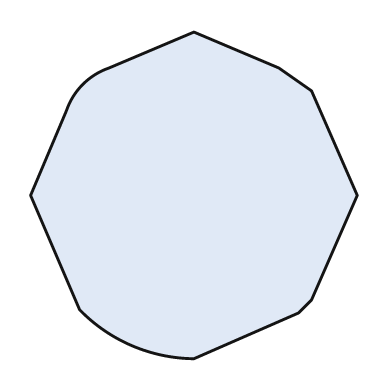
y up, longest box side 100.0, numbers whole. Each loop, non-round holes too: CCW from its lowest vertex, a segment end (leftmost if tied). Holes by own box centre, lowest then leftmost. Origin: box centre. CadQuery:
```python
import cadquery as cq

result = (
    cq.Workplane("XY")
    .moveTo(0.0, -50.0)
    .lineTo(32.0, -36.0)
    .lineTo(36.0, -32.0)
    .lineTo(50.0, 0.0)
    .lineTo(36.0, 32.0)
    .lineTo(26.0, 39.0)
    .lineTo(0.0, 50.0)
    .lineTo(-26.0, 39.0)
    .threePointArc((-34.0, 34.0), (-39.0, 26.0))
    .lineTo(-50.0, 0.0)
    .lineTo(-35.0, -35.0)
    .threePointArc((-19.0, -46.0), (0.0, -50.0))
    .close()
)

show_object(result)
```